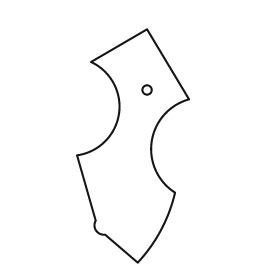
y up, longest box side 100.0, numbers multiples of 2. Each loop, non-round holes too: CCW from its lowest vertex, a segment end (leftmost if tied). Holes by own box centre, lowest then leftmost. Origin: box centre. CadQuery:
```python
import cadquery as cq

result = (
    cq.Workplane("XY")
    .moveTo(2.0, -50.0)
    .threePointArc((12.0, -36.0), (18.0, -20.0))
    .threePointArc((8.0, 2.0), (24.0, 20.0))
    .lineTo(6.0, 50.0)
    .lineTo(-18.0, 36.0)
    .threePointArc((-6.0, 14.0), (-24.0, -4.0))
    .lineTo(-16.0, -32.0)
    .threePointArc((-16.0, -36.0), (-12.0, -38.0))
    .close()
    .moveTo(6.0, 24.0)
    .circle(2.0)
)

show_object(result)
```